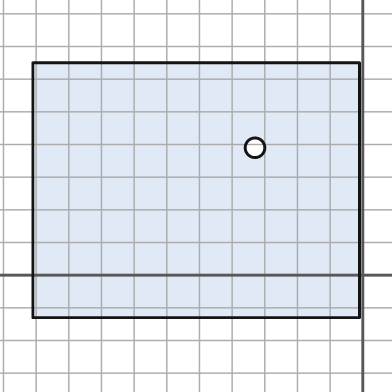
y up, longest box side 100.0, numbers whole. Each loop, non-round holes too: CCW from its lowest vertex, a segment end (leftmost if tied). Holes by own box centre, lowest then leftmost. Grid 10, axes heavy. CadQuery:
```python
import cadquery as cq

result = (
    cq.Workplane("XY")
    .moveTo(-101.0, -13.0)
    .lineTo(-1.0, -13.0)
    .lineTo(-1.0, 65.0)
    .lineTo(-101.0, 65.0)
    .close()
    .moveTo(-33.0, 39.0)
    .circle(3.0)
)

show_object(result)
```